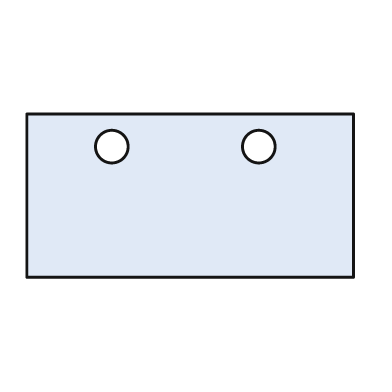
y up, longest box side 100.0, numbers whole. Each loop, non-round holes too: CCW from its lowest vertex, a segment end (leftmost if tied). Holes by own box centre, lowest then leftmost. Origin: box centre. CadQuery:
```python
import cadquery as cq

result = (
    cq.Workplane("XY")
    .moveTo(-50.0, -25.0)
    .lineTo(50.0, -25.0)
    .lineTo(50.0, 25.0)
    .lineTo(-50.0, 25.0)
    .close()
    .moveTo(-24.0, 15.0)
    .circle(5.0)
    .moveTo(21.0, 15.0)
    .circle(5.0)
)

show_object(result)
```